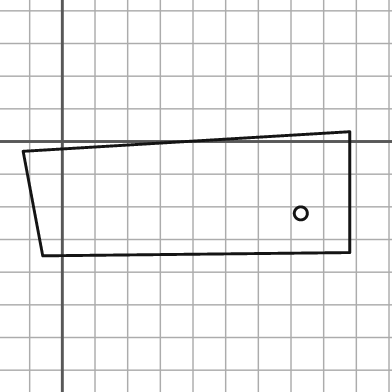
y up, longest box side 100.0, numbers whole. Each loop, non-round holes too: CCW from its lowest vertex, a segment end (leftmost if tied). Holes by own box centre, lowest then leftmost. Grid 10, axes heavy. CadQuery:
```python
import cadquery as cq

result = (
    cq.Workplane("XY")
    .moveTo(-6.0, -35.0)
    .lineTo(88.0, -34.0)
    .lineTo(88.0, 3.0)
    .lineTo(-12.0, -3.0)
    .close()
    .moveTo(73.0, -22.0)
    .circle(2.0)
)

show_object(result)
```